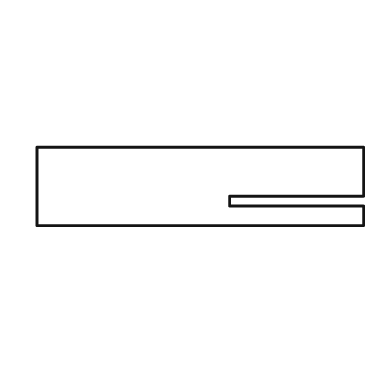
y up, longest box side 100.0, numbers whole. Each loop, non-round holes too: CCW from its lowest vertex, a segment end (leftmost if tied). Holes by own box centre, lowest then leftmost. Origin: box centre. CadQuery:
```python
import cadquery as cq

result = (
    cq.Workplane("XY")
    .moveTo(-50.0, -12.0)
    .lineTo(50.0, -12.0)
    .lineTo(50.0, -6.0)
    .lineTo(9.0, -6.0)
    .lineTo(9.0, -3.0)
    .lineTo(50.0, -3.0)
    .lineTo(50.0, 12.0)
    .lineTo(-50.0, 12.0)
    .close()
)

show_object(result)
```